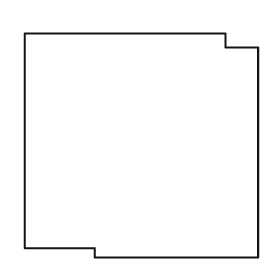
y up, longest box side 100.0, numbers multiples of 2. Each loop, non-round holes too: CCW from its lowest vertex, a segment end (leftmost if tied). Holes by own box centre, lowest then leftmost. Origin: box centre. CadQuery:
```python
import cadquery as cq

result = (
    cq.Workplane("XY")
    .moveTo(-20.0, -48.0)
    .lineTo(50.0, -48.0)
    .lineTo(50.0, 42.0)
    .lineTo(36.0, 42.0)
    .lineTo(36.0, 48.0)
    .lineTo(-50.0, 48.0)
    .lineTo(-50.0, -44.0)
    .lineTo(-20.0, -44.0)
    .close()
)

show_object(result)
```